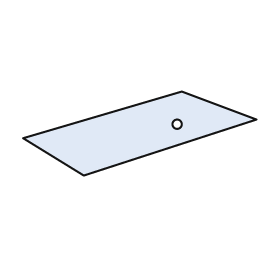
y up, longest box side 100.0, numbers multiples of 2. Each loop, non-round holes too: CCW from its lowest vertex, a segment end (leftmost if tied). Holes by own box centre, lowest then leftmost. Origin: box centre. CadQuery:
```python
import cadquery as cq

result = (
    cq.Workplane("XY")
    .moveTo(-24.0, -18.0)
    .lineTo(50.0, 6.0)
    .lineTo(18.0, 18.0)
    .lineTo(-50.0, -2.0)
    .close()
    .moveTo(16.0, 4.0)
    .circle(2.0)
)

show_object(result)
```